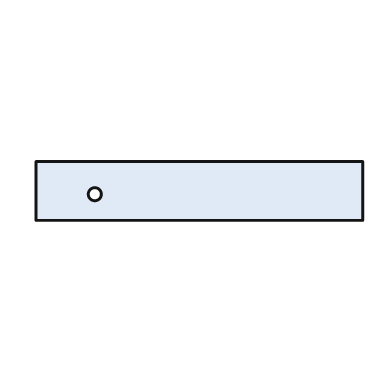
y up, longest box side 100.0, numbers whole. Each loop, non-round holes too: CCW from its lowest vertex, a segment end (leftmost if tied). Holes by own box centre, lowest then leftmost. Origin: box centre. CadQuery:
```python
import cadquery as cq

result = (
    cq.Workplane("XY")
    .moveTo(-50.0, -9.0)
    .lineTo(50.0, -9.0)
    .lineTo(50.0, 9.0)
    .lineTo(-50.0, 9.0)
    .close()
    .moveTo(-32.0, -1.0)
    .circle(2.0)
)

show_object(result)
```